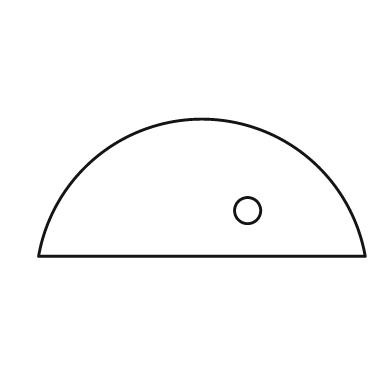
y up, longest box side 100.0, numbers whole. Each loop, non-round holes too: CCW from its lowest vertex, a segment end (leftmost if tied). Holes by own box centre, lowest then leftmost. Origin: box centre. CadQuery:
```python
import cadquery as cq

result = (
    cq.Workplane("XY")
    .moveTo(-50.0, -21.0)
    .lineTo(50.0, -21.0)
    .threePointArc((0.0, 21.0), (-50.0, -21.0))
    .close()
    .moveTo(14.0, -7.0)
    .circle(4.0)
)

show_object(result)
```